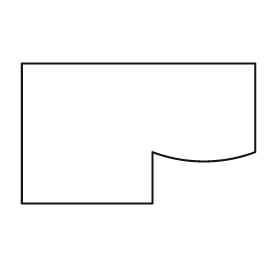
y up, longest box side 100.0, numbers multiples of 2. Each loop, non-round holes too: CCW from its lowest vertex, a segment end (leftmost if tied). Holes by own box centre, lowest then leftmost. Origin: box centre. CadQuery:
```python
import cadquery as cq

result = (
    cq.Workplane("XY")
    .moveTo(-50.0, -30.0)
    .lineTo(6.0, -30.0)
    .lineTo(6.0, -8.0)
    .threePointArc((28.0, -12.0), (50.0, -8.0))
    .lineTo(50.0, 30.0)
    .lineTo(-50.0, 30.0)
    .close()
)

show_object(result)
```